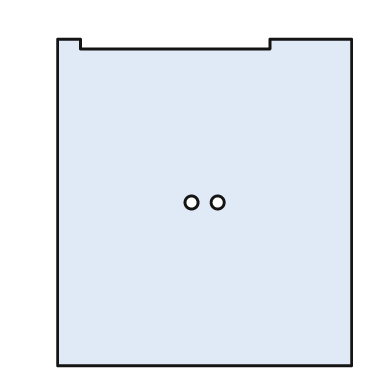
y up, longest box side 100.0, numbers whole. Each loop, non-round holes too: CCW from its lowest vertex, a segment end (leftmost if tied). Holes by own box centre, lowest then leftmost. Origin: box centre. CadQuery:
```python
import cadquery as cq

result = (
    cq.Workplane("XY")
    .moveTo(-45.0, -50.0)
    .lineTo(45.0, -50.0)
    .lineTo(45.0, 50.0)
    .lineTo(20.0, 50.0)
    .lineTo(20.0, 47.0)
    .lineTo(-38.0, 47.0)
    .lineTo(-38.0, 50.0)
    .lineTo(-45.0, 50.0)
    .close()
    .moveTo(-4.0, 0.0)
    .circle(2.0)
    .moveTo(4.0, 0.0)
    .circle(2.0)
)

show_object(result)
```